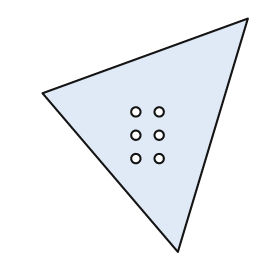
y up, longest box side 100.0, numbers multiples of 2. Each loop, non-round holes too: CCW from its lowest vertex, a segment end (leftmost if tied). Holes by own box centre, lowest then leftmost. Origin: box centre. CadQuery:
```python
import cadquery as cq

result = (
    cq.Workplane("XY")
    .moveTo(14.0, -50.0)
    .lineTo(44.0, 50.0)
    .lineTo(-44.0, 18.0)
    .close()
    .moveTo(-4.0, -10.0)
    .circle(2.0)
    .moveTo(6.0, -10.0)
    .circle(2.0)
    .moveTo(-4.0, 0.0)
    .circle(2.0)
    .moveTo(6.0, 0.0)
    .circle(2.0)
    .moveTo(-4.0, 10.0)
    .circle(2.0)
    .moveTo(6.0, 10.0)
    .circle(2.0)
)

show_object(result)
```